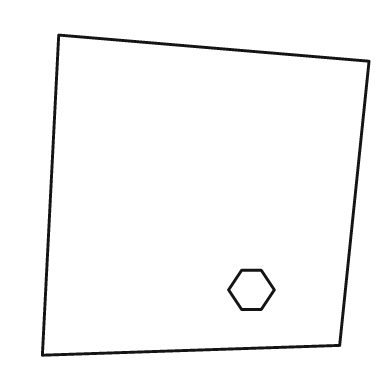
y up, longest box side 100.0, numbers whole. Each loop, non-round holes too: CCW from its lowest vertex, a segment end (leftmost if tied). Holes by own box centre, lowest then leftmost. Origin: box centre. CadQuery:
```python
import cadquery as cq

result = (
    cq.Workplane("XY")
    .moveTo(-50.0, -49.0)
    .lineTo(41.0, -46.0)
    .lineTo(50.0, 41.0)
    .lineTo(-45.0, 49.0)
    .close()
    .moveTo(11.0, -35.0)
    .lineTo(17.0, -35.0)
    .lineTo(21.0, -29.0)
    .lineTo(17.0, -23.0)
    .lineTo(11.0, -23.0)
    .lineTo(7.0, -29.0)
    .close()
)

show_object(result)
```